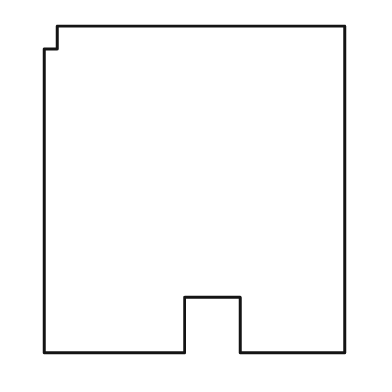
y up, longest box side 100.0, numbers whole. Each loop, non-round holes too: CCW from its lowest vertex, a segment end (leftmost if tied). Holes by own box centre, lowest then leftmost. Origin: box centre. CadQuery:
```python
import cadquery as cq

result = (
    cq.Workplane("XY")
    .moveTo(-46.0, -50.0)
    .lineTo(-3.0, -50.0)
    .lineTo(-3.0, -33.0)
    .lineTo(14.0, -33.0)
    .lineTo(14.0, -50.0)
    .lineTo(46.0, -50.0)
    .lineTo(46.0, 50.0)
    .lineTo(-42.0, 50.0)
    .lineTo(-42.0, 43.0)
    .lineTo(-46.0, 43.0)
    .close()
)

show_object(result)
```